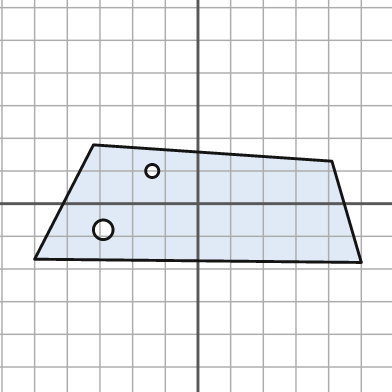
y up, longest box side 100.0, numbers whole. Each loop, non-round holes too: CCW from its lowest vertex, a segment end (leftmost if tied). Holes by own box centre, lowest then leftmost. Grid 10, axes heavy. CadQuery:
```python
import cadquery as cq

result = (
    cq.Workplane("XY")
    .moveTo(50.0, -18.0)
    .lineTo(41.0, 13.0)
    .lineTo(-32.0, 18.0)
    .lineTo(-50.0, -17.0)
    .close()
    .moveTo(-29.0, -8.0)
    .circle(3.0)
    .moveTo(-14.0, 10.0)
    .circle(2.0)
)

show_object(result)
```